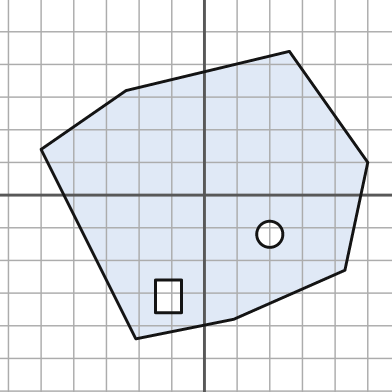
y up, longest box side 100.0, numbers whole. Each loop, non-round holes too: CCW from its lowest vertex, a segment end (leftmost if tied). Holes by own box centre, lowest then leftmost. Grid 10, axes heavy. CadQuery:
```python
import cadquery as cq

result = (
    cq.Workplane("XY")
    .moveTo(-21.0, -44.0)
    .lineTo(9.0, -38.0)
    .lineTo(43.0, -23.0)
    .lineTo(50.0, 10.0)
    .lineTo(26.0, 44.0)
    .lineTo(-24.0, 32.0)
    .lineTo(-50.0, 14.0)
    .close()
    .moveTo(-15.0, -36.0)
    .lineTo(-7.0, -36.0)
    .lineTo(-7.0, -26.0)
    .lineTo(-15.0, -26.0)
    .close()
    .moveTo(20.0, -12.0)
    .circle(4.0)
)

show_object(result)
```